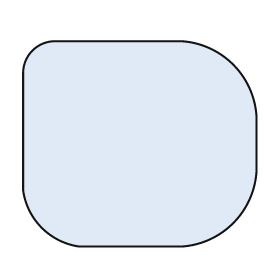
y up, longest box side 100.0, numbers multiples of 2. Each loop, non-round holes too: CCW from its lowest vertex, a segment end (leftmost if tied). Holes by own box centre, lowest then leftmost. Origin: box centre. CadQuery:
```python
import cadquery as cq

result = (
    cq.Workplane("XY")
    .moveTo(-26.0, -44.0)
    .lineTo(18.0, -44.0)
    .threePointArc((40.0, -34.0), (50.0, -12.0))
    .lineTo(50.0, 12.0)
    .threePointArc((40.0, 34.0), (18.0, 44.0))
    .lineTo(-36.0, 44.0)
    .threePointArc((-46.0, 40.0), (-50.0, 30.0))
    .lineTo(-50.0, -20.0)
    .threePointArc((-42.0, -36.0), (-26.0, -44.0))
    .close()
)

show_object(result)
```